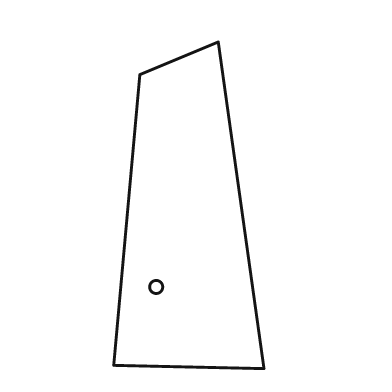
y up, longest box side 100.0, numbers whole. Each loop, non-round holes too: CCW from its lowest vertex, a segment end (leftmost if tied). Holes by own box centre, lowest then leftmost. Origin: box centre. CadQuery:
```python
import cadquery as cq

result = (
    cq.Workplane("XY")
    .moveTo(23.0, -50.0)
    .lineTo(9.0, 50.0)
    .lineTo(-15.0, 40.0)
    .lineTo(-23.0, -49.0)
    .close()
    .moveTo(-10.0, -25.0)
    .circle(2.0)
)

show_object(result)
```